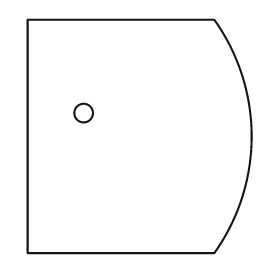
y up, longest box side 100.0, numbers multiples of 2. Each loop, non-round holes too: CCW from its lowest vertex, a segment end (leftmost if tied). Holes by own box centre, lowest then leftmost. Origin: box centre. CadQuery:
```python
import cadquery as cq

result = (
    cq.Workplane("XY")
    .moveTo(-48.0, -50.0)
    .lineTo(32.0, -50.0)
    .threePointArc((48.0, 0.0), (32.0, 50.0))
    .lineTo(-48.0, 50.0)
    .close()
    .moveTo(-24.0, 10.0)
    .circle(4.0)
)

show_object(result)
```